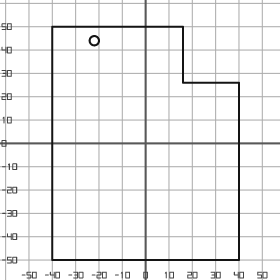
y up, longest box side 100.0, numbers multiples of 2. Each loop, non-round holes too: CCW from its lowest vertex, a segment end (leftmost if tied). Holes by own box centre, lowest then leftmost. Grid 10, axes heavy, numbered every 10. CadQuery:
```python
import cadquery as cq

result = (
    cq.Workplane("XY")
    .moveTo(-40.0, -50.0)
    .lineTo(40.0, -50.0)
    .lineTo(40.0, 26.0)
    .lineTo(16.0, 26.0)
    .lineTo(16.0, 50.0)
    .lineTo(-40.0, 50.0)
    .close()
    .moveTo(-22.0, 44.0)
    .circle(2.0)
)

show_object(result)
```